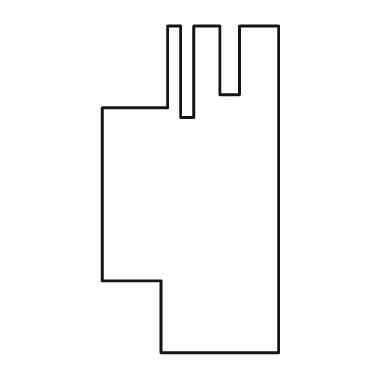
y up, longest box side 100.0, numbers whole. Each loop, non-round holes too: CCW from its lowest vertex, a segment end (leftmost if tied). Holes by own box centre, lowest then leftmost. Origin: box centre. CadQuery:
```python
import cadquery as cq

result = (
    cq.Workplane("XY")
    .moveTo(-9.0, -50.0)
    .lineTo(27.0, -50.0)
    .lineTo(27.0, 50.0)
    .lineTo(15.0, 50.0)
    .lineTo(15.0, 29.0)
    .lineTo(9.0, 29.0)
    .lineTo(9.0, 50.0)
    .lineTo(1.0, 50.0)
    .lineTo(1.0, 22.0)
    .lineTo(-3.0, 22.0)
    .lineTo(-3.0, 50.0)
    .lineTo(-7.0, 50.0)
    .lineTo(-7.0, 25.0)
    .lineTo(-27.0, 25.0)
    .lineTo(-27.0, -28.0)
    .lineTo(-9.0, -28.0)
    .close()
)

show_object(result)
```